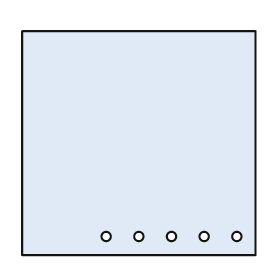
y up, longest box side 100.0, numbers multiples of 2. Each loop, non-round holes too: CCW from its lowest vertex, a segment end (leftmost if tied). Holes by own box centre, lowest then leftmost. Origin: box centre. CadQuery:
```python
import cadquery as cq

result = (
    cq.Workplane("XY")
    .moveTo(-50.0, -48.0)
    .lineTo(50.0, -48.0)
    .lineTo(50.0, 48.0)
    .lineTo(-50.0, 48.0)
    .close()
    .moveTo(-14.0, -40.0)
    .circle(2.0)
    .moveTo(0.0, -40.0)
    .circle(2.0)
    .moveTo(14.0, -40.0)
    .circle(2.0)
    .moveTo(28.0, -40.0)
    .circle(2.0)
    .moveTo(42.0, -40.0)
    .circle(2.0)
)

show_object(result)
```